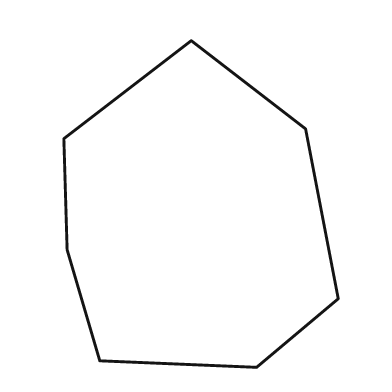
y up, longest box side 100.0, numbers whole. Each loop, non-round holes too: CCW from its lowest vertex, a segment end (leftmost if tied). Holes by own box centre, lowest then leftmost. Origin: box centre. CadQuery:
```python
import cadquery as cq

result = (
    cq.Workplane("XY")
    .moveTo(17.0, -50.0)
    .lineTo(42.0, -29.0)
    .lineTo(32.0, 23.0)
    .lineTo(-3.0, 50.0)
    .lineTo(-42.0, 20.0)
    .lineTo(-41.0, -14.0)
    .lineTo(-31.0, -48.0)
    .close()
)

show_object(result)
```